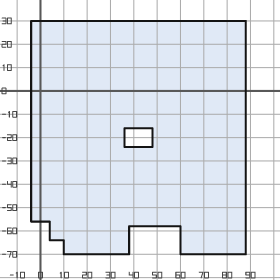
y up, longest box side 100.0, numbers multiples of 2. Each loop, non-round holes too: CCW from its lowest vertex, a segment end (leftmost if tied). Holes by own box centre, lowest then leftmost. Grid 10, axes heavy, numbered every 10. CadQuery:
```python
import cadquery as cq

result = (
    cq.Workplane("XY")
    .moveTo(10.0, -70.0)
    .lineTo(38.0, -70.0)
    .lineTo(38.0, -58.0)
    .lineTo(60.0, -58.0)
    .lineTo(60.0, -70.0)
    .lineTo(88.0, -70.0)
    .lineTo(88.0, 30.0)
    .lineTo(-4.0, 30.0)
    .lineTo(-4.0, -56.0)
    .lineTo(4.0, -56.0)
    .lineTo(4.0, -64.0)
    .lineTo(10.0, -64.0)
    .close()
    .moveTo(36.0, -24.0)
    .lineTo(48.0, -24.0)
    .lineTo(48.0, -16.0)
    .lineTo(36.0, -16.0)
    .close()
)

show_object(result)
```